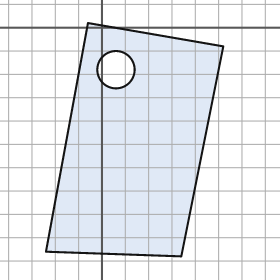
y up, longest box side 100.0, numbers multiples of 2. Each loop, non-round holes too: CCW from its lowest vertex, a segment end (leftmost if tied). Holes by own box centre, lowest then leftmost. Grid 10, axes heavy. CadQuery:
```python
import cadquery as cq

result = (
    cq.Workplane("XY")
    .moveTo(34.0, -98.0)
    .lineTo(52.0, -8.0)
    .lineTo(-6.0, 2.0)
    .lineTo(-24.0, -96.0)
    .close()
    .moveTo(6.0, -18.0)
    .circle(8.0)
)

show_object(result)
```